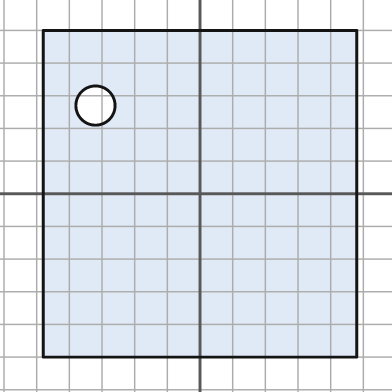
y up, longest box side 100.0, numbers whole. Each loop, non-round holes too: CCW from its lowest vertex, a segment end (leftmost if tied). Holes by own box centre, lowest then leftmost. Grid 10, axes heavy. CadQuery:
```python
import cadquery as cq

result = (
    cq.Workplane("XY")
    .moveTo(-48.0, -50.0)
    .lineTo(48.0, -50.0)
    .lineTo(48.0, 50.0)
    .lineTo(-48.0, 50.0)
    .close()
    .moveTo(-32.0, 27.0)
    .circle(6.0)
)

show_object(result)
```